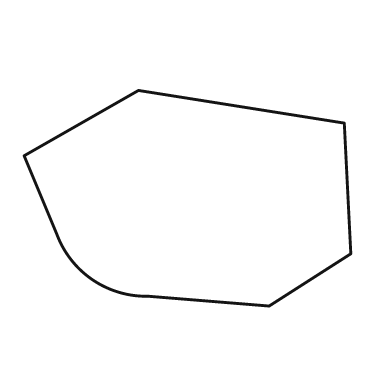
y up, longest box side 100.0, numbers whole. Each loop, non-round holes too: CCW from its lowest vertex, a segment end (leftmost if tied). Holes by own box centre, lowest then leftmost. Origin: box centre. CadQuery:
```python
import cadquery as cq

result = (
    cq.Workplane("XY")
    .moveTo(25.0, -33.0)
    .lineTo(50.0, -17.0)
    .lineTo(48.0, 23.0)
    .lineTo(-15.0, 33.0)
    .lineTo(-50.0, 13.0)
    .lineTo(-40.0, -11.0)
    .threePointArc((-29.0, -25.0), (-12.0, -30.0))
    .close()
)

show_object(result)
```